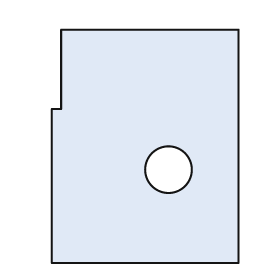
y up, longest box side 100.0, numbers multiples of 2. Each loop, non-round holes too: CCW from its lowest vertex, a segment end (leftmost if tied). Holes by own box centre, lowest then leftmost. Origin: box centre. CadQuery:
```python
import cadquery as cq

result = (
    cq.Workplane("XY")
    .moveTo(-40.0, -50.0)
    .lineTo(40.0, -50.0)
    .lineTo(40.0, 50.0)
    .lineTo(-36.0, 50.0)
    .lineTo(-36.0, 16.0)
    .lineTo(-40.0, 16.0)
    .close()
    .moveTo(10.0, -10.0)
    .circle(10.0)
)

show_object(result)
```